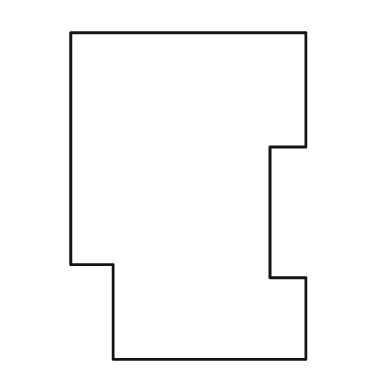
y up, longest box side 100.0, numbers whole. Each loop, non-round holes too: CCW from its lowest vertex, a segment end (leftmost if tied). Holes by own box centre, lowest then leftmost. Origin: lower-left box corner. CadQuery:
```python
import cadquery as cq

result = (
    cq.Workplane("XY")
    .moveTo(13.0, 0.0)
    .lineTo(72.0, 0.0)
    .lineTo(72.0, 25.0)
    .lineTo(61.0, 25.0)
    .lineTo(61.0, 65.0)
    .lineTo(72.0, 65.0)
    .lineTo(72.0, 100.0)
    .lineTo(0.0, 100.0)
    .lineTo(0.0, 29.0)
    .lineTo(13.0, 29.0)
    .close()
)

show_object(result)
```